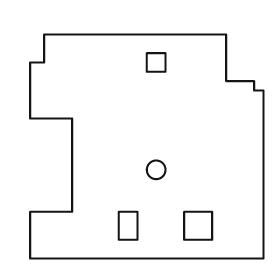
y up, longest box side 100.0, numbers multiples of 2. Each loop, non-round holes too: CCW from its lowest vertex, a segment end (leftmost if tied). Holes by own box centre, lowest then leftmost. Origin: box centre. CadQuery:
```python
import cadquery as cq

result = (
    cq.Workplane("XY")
    .moveTo(-50.0, -48.0)
    .lineTo(50.0, -48.0)
    .lineTo(50.0, 24.0)
    .lineTo(46.0, 24.0)
    .lineTo(46.0, 28.0)
    .lineTo(34.0, 28.0)
    .lineTo(34.0, 48.0)
    .lineTo(-44.0, 48.0)
    .lineTo(-44.0, 36.0)
    .lineTo(-50.0, 36.0)
    .lineTo(-50.0, 12.0)
    .lineTo(-32.0, 12.0)
    .lineTo(-32.0, -28.0)
    .lineTo(-50.0, -28.0)
    .close()
    .moveTo(-12.0, -40.0)
    .lineTo(-4.0, -40.0)
    .lineTo(-4.0, -28.0)
    .lineTo(-12.0, -28.0)
    .close()
    .moveTo(16.0, -40.0)
    .lineTo(28.0, -40.0)
    .lineTo(28.0, -28.0)
    .lineTo(16.0, -28.0)
    .close()
    .moveTo(4.0, -10.0)
    .circle(4.0)
    .moveTo(0.0, 32.0)
    .lineTo(8.0, 32.0)
    .lineTo(8.0, 40.0)
    .lineTo(0.0, 40.0)
    .close()
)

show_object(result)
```